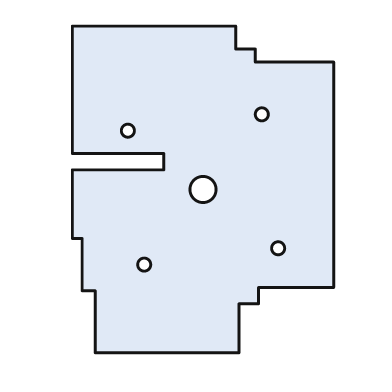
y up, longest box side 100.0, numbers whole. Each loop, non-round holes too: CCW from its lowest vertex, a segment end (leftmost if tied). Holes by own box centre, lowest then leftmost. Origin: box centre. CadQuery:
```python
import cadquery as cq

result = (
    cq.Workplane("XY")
    .moveTo(-33.0, -50.0)
    .lineTo(11.0, -50.0)
    .lineTo(11.0, -35.0)
    .lineTo(17.0, -35.0)
    .lineTo(17.0, -30.0)
    .lineTo(40.0, -30.0)
    .lineTo(40.0, 39.0)
    .lineTo(16.0, 39.0)
    .lineTo(16.0, 43.0)
    .lineTo(10.0, 43.0)
    .lineTo(10.0, 50.0)
    .lineTo(-40.0, 50.0)
    .lineTo(-40.0, 11.0)
    .lineTo(-12.0, 11.0)
    .lineTo(-12.0, 6.0)
    .lineTo(-40.0, 6.0)
    .lineTo(-40.0, -15.0)
    .lineTo(-37.0, -15.0)
    .lineTo(-37.0, -31.0)
    .lineTo(-33.0, -31.0)
    .close()
    .moveTo(-18.0, -23.0)
    .circle(2.0)
    .moveTo(23.0, -18.0)
    .circle(2.0)
    .moveTo(0.0, 0.0)
    .circle(4.0)
    .moveTo(-23.0, 18.0)
    .circle(2.0)
    .moveTo(18.0, 23.0)
    .circle(2.0)
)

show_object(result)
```